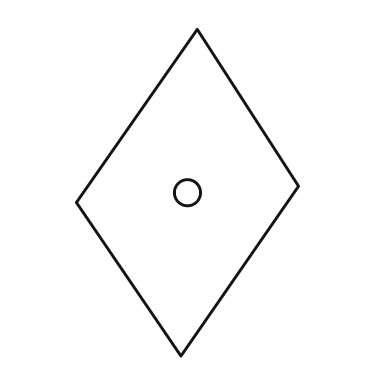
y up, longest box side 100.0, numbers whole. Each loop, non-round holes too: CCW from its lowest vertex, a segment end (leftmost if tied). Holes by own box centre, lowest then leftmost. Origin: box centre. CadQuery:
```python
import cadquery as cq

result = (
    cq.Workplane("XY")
    .moveTo(-2.0, -50.0)
    .lineTo(34.0, 2.0)
    .lineTo(3.0, 50.0)
    .lineTo(-34.0, -3.0)
    .close()
    .moveTo(0.0, 0.0)
    .circle(4.0)
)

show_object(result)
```